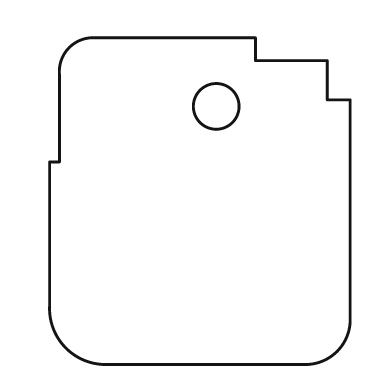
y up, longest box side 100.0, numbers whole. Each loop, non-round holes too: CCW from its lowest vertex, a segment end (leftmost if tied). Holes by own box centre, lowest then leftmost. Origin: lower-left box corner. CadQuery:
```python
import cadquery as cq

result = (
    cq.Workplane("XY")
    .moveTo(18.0, 0.0)
    .lineTo(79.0, 0.0)
    .threePointArc((88.0, 4.0), (92.0, 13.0))
    .lineTo(92.0, 81.0)
    .lineTo(85.0, 81.0)
    .lineTo(85.0, 93.0)
    .lineTo(63.0, 93.0)
    .lineTo(63.0, 100.0)
    .lineTo(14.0, 100.0)
    .threePointArc((6.0, 97.0), (3.0, 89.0))
    .lineTo(3.0, 62.0)
    .lineTo(0.0, 62.0)
    .lineTo(0.0, 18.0)
    .threePointArc((5.0, 5.0), (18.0, 0.0))
    .close()
    .moveTo(51.0, 79.0)
    .circle(7.0)
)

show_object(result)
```